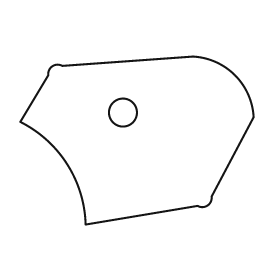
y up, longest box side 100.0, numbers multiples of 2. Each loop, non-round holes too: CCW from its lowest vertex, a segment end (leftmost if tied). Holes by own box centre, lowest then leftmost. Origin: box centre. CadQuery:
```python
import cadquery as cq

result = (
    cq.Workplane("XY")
    .moveTo(-22.0, -36.0)
    .lineTo(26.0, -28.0)
    .threePointArc((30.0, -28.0), (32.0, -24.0))
    .lineTo(50.0, 10.0)
    .threePointArc((42.0, 28.0), (24.0, 36.0))
    .lineTo(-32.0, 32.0)
    .threePointArc((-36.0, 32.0), (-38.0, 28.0))
    .lineTo(-50.0, 8.0)
    .threePointArc((-30.0, -10.0), (-22.0, -36.0))
    .close()
    .moveTo(-6.0, 12.0)
    .circle(6.0)
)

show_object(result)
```